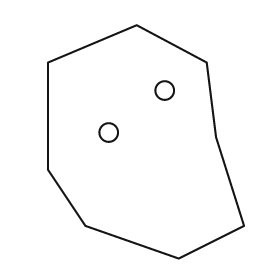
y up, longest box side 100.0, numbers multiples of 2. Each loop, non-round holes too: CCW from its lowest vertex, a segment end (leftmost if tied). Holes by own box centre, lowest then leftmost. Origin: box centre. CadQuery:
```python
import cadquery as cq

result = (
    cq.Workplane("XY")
    .moveTo(14.0, -50.0)
    .lineTo(42.0, -36.0)
    .lineTo(30.0, 2.0)
    .lineTo(26.0, 34.0)
    .lineTo(-4.0, 50.0)
    .lineTo(-42.0, 34.0)
    .lineTo(-42.0, -12.0)
    .lineTo(-26.0, -36.0)
    .close()
    .moveTo(-16.0, 4.0)
    .circle(4.0)
    .moveTo(8.0, 22.0)
    .circle(4.0)
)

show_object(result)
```